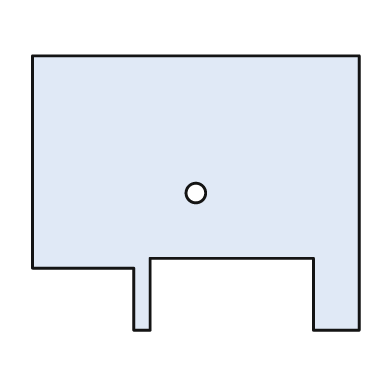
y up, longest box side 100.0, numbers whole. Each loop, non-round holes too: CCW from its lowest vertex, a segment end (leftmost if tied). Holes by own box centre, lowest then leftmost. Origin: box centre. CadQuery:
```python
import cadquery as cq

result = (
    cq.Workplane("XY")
    .moveTo(-19.0, -42.0)
    .lineTo(-14.0, -42.0)
    .lineTo(-14.0, -20.0)
    .lineTo(36.0, -20.0)
    .lineTo(36.0, -42.0)
    .lineTo(50.0, -42.0)
    .lineTo(50.0, 42.0)
    .lineTo(-50.0, 42.0)
    .lineTo(-50.0, -23.0)
    .lineTo(-19.0, -23.0)
    .close()
    .moveTo(0.0, 0.0)
    .circle(3.0)
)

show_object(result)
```